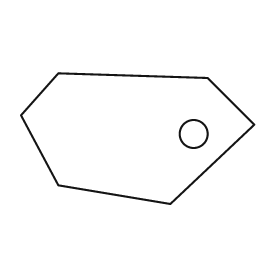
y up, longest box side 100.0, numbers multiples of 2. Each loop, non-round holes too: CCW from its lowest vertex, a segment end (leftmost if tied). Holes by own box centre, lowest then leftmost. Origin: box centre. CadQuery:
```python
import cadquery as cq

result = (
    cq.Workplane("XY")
    .moveTo(14.0, -28.0)
    .lineTo(50.0, 6.0)
    .lineTo(30.0, 26.0)
    .lineTo(-34.0, 28.0)
    .lineTo(-50.0, 10.0)
    .lineTo(-34.0, -20.0)
    .close()
    .moveTo(24.0, 2.0)
    .circle(6.0)
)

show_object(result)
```